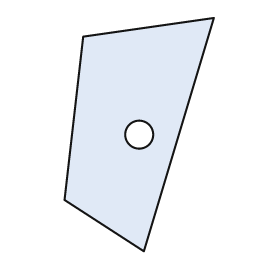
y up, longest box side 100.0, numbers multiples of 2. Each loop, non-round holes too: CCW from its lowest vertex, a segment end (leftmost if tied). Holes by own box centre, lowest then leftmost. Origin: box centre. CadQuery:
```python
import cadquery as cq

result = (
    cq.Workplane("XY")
    .moveTo(2.0, -50.0)
    .lineTo(32.0, 50.0)
    .lineTo(-24.0, 42.0)
    .lineTo(-32.0, -28.0)
    .close()
    .moveTo(0.0, 0.0)
    .circle(6.0)
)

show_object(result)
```